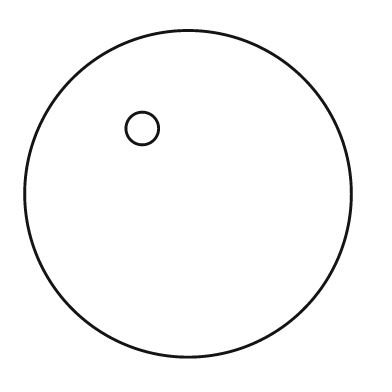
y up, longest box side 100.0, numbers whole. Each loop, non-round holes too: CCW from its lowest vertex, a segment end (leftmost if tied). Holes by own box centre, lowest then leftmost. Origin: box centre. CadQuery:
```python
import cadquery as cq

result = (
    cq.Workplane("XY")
    .moveTo(0.0, 0.0)
    .circle(50.0)
    .moveTo(-14.0, 20.0)
    .circle(5.0)
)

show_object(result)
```